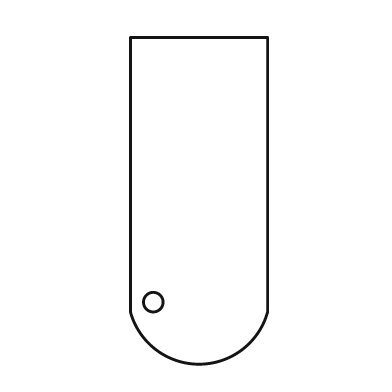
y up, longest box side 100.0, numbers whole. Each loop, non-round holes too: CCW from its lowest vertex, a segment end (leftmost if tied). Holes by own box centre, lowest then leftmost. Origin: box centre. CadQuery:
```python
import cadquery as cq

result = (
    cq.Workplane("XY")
    .moveTo(-21.0, -34.0)
    .threePointArc((0.0, -50.0), (21.0, -34.0))
    .lineTo(21.0, 50.0)
    .lineTo(-21.0, 50.0)
    .close()
    .moveTo(-14.0, -31.0)
    .circle(3.0)
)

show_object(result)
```